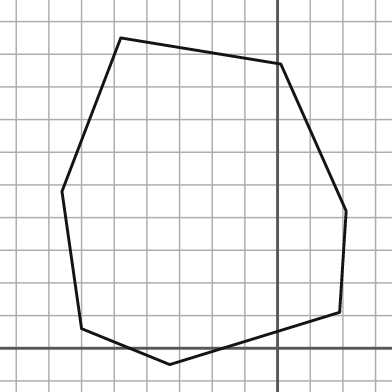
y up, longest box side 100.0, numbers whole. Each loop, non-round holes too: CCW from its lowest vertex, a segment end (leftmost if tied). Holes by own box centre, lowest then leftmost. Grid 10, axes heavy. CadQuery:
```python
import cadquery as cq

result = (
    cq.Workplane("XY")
    .moveTo(-33.0, -5.0)
    .lineTo(19.0, 11.0)
    .lineTo(21.0, 42.0)
    .lineTo(1.0, 87.0)
    .lineTo(-48.0, 95.0)
    .lineTo(-66.0, 48.0)
    .lineTo(-60.0, 6.0)
    .close()
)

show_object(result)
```